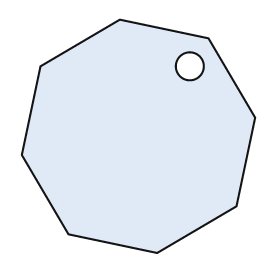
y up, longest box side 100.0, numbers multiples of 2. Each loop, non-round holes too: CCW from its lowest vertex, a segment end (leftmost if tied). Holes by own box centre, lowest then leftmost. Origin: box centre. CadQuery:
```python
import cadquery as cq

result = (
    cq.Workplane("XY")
    .moveTo(8.0, -50.0)
    .lineTo(42.0, -30.0)
    .lineTo(50.0, 8.0)
    .lineTo(30.0, 42.0)
    .lineTo(-8.0, 50.0)
    .lineTo(-42.0, 30.0)
    .lineTo(-50.0, -8.0)
    .lineTo(-30.0, -42.0)
    .close()
    .moveTo(22.0, 30.0)
    .circle(6.0)
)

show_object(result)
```